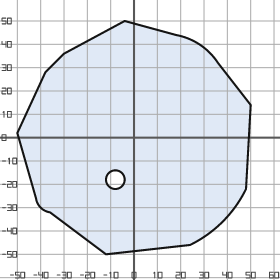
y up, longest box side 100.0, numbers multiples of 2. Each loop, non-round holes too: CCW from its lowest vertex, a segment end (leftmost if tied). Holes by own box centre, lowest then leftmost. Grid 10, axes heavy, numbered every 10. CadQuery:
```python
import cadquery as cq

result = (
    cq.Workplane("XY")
    .moveTo(-12.0, -50.0)
    .lineTo(24.0, -46.0)
    .threePointArc((38.0, -36.0), (48.0, -22.0))
    .lineTo(50.0, 14.0)
    .lineTo(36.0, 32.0)
    .threePointArc((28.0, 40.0), (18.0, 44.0))
    .lineTo(-4.0, 50.0)
    .lineTo(-30.0, 36.0)
    .lineTo(-38.0, 28.0)
    .lineTo(-50.0, 2.0)
    .lineTo(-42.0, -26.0)
    .threePointArc((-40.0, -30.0), (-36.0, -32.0))
    .close()
    .moveTo(-8.0, -18.0)
    .circle(4.0)
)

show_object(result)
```